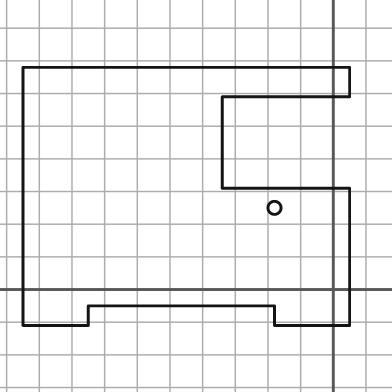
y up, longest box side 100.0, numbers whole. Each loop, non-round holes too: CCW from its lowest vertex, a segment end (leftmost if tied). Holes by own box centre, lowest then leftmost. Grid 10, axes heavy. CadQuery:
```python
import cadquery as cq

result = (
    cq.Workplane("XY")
    .moveTo(-95.0, -11.0)
    .lineTo(-75.0, -11.0)
    .lineTo(-75.0, -5.0)
    .lineTo(-18.0, -5.0)
    .lineTo(-18.0, -11.0)
    .lineTo(5.0, -11.0)
    .lineTo(5.0, 31.0)
    .lineTo(-34.0, 31.0)
    .lineTo(-34.0, 59.0)
    .lineTo(5.0, 59.0)
    .lineTo(5.0, 68.0)
    .lineTo(-95.0, 68.0)
    .close()
    .moveTo(-18.0, 25.0)
    .circle(2.0)
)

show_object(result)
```